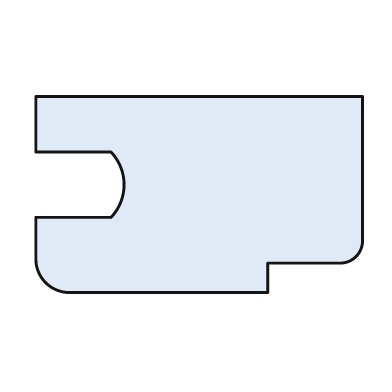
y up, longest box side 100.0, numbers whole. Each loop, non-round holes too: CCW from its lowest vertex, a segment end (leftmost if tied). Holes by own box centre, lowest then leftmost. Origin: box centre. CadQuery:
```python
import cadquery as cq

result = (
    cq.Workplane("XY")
    .moveTo(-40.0, -30.0)
    .lineTo(21.0, -30.0)
    .lineTo(21.0, -21.0)
    .lineTo(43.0, -21.0)
    .threePointArc((48.0, -19.0), (50.0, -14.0))
    .lineTo(50.0, 30.0)
    .lineTo(-50.0, 30.0)
    .lineTo(-50.0, 13.0)
    .lineTo(-27.0, 13.0)
    .threePointArc((-23.0, 3.0), (-27.0, -7.0))
    .lineTo(-50.0, -7.0)
    .lineTo(-50.0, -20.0)
    .threePointArc((-47.0, -27.0), (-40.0, -30.0))
    .close()
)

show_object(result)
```